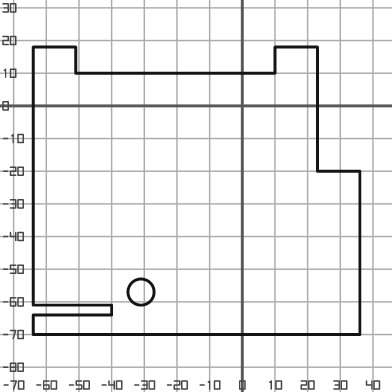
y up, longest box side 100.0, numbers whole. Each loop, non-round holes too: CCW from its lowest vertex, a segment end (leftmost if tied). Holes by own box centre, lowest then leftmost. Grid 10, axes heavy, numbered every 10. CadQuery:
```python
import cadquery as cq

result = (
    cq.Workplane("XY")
    .moveTo(-64.0, -70.0)
    .lineTo(36.0, -70.0)
    .lineTo(36.0, -20.0)
    .lineTo(23.0, -20.0)
    .lineTo(23.0, 18.0)
    .lineTo(10.0, 18.0)
    .lineTo(10.0, 10.0)
    .lineTo(-51.0, 10.0)
    .lineTo(-51.0, 18.0)
    .lineTo(-64.0, 18.0)
    .lineTo(-64.0, -61.0)
    .lineTo(-40.0, -61.0)
    .lineTo(-40.0, -64.0)
    .lineTo(-64.0, -64.0)
    .close()
    .moveTo(-31.0, -57.0)
    .circle(4.0)
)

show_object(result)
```